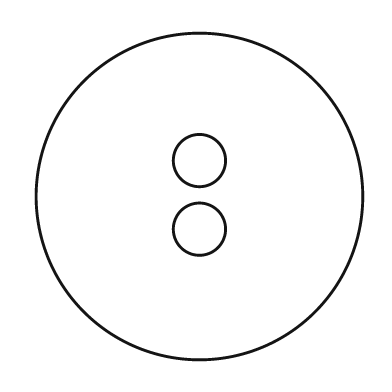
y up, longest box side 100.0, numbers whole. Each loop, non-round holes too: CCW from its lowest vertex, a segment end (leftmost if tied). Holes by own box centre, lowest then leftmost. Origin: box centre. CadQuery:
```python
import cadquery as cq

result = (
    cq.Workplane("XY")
    .moveTo(0.0, 0.0)
    .circle(50.0)
    .moveTo(0.0, -10.0)
    .circle(8.0)
    .moveTo(0.0, 11.0)
    .circle(8.0)
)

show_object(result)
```